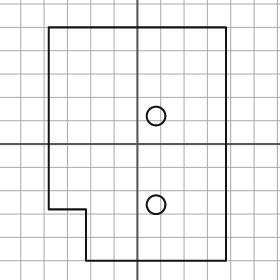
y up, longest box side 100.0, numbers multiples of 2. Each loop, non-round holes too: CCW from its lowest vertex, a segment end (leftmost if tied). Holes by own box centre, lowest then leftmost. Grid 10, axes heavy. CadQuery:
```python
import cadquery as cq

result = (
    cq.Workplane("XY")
    .moveTo(-22.0, -50.0)
    .lineTo(38.0, -50.0)
    .lineTo(38.0, 50.0)
    .lineTo(-38.0, 50.0)
    .lineTo(-38.0, -28.0)
    .lineTo(-22.0, -28.0)
    .close()
    .moveTo(8.0, -26.0)
    .circle(4.0)
    .moveTo(8.0, 12.0)
    .circle(4.0)
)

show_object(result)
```